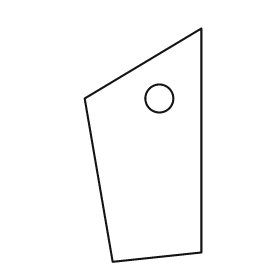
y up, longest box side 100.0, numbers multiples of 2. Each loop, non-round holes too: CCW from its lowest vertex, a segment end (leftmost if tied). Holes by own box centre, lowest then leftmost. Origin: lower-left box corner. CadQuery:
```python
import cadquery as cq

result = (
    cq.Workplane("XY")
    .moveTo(12.0, 0.0)
    .lineTo(50.0, 4.0)
    .lineTo(50.0, 100.0)
    .lineTo(0.0, 70.0)
    .close()
    .moveTo(32.0, 70.0)
    .circle(6.0)
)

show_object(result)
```